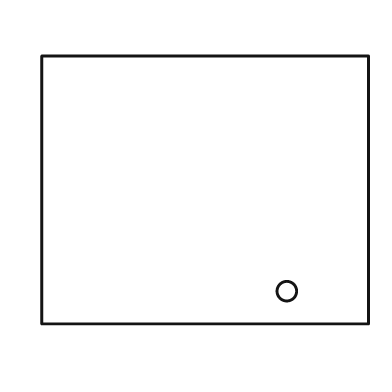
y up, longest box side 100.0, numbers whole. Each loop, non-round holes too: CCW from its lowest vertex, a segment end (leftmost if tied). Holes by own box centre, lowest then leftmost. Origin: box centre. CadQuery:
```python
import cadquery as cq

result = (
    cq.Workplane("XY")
    .moveTo(-50.0, -41.0)
    .lineTo(50.0, -41.0)
    .lineTo(50.0, 41.0)
    .lineTo(-50.0, 41.0)
    .close()
    .moveTo(25.0, -31.0)
    .circle(3.0)
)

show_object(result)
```